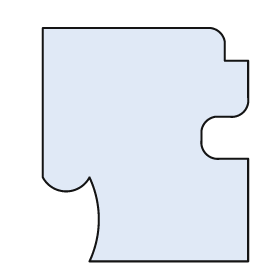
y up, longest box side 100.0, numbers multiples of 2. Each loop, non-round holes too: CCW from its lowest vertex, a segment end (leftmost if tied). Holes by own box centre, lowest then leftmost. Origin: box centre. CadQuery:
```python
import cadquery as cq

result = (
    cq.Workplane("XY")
    .moveTo(-24.0, -50.0)
    .lineTo(44.0, -50.0)
    .lineTo(44.0, -6.0)
    .lineTo(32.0, -6.0)
    .threePointArc((26.0, -4.0), (24.0, 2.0))
    .lineTo(24.0, 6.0)
    .threePointArc((26.0, 10.0), (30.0, 12.0))
    .lineTo(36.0, 12.0)
    .threePointArc((42.0, 14.0), (44.0, 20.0))
    .lineTo(44.0, 36.0)
    .lineTo(34.0, 36.0)
    .lineTo(34.0, 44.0)
    .threePointArc((32.0, 48.0), (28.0, 50.0))
    .lineTo(-44.0, 50.0)
    .lineTo(-44.0, -14.0)
    .threePointArc((-34.0, -20.0), (-24.0, -14.0))
    .threePointArc((-20.0, -32.0), (-24.0, -50.0))
    .close()
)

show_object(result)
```